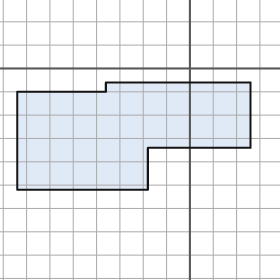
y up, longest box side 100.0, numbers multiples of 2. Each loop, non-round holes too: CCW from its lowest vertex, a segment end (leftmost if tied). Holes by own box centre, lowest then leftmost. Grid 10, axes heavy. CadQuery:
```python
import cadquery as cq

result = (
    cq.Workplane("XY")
    .moveTo(-74.0, -52.0)
    .lineTo(-18.0, -52.0)
    .lineTo(-18.0, -34.0)
    .lineTo(26.0, -34.0)
    .lineTo(26.0, -6.0)
    .lineTo(-36.0, -6.0)
    .lineTo(-36.0, -10.0)
    .lineTo(-74.0, -10.0)
    .close()
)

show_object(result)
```